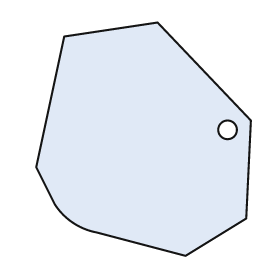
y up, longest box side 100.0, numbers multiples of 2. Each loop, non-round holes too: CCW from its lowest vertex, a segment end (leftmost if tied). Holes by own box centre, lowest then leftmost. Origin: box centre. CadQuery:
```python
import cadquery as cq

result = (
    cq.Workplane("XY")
    .moveTo(18.0, -50.0)
    .lineTo(44.0, -34.0)
    .lineTo(46.0, 8.0)
    .lineTo(6.0, 50.0)
    .lineTo(-34.0, 44.0)
    .lineTo(-46.0, -12.0)
    .lineTo(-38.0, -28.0)
    .threePointArc((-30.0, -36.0), (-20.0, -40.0))
    .close()
    .moveTo(36.0, 4.0)
    .circle(4.0)
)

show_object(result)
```